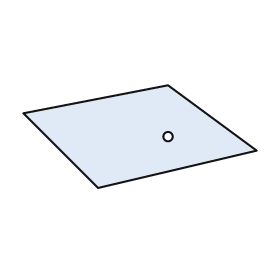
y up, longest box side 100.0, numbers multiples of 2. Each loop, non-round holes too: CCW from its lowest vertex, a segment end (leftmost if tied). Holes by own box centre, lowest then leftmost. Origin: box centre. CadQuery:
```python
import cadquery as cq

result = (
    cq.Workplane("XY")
    .moveTo(-18.0, -22.0)
    .lineTo(50.0, -6.0)
    .lineTo(12.0, 22.0)
    .lineTo(-50.0, 10.0)
    .close()
    .moveTo(12.0, 0.0)
    .circle(2.0)
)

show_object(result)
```